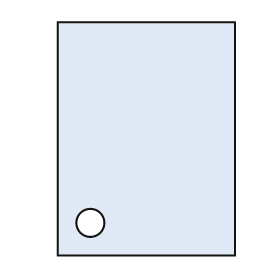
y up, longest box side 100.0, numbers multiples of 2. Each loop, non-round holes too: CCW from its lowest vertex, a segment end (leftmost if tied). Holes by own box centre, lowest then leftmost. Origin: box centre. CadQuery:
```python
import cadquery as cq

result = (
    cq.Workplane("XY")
    .moveTo(-38.0, -50.0)
    .lineTo(38.0, -50.0)
    .lineTo(38.0, 50.0)
    .lineTo(-38.0, 50.0)
    .close()
    .moveTo(-24.0, -36.0)
    .circle(6.0)
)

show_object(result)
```